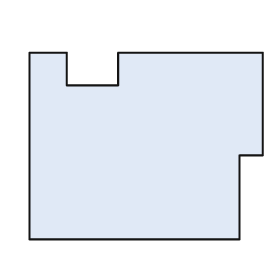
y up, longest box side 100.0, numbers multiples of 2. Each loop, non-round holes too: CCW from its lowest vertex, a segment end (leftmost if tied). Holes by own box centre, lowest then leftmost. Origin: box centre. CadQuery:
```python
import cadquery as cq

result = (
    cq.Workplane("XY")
    .moveTo(-50.0, -40.0)
    .lineTo(40.0, -40.0)
    .lineTo(40.0, -4.0)
    .lineTo(50.0, -4.0)
    .lineTo(50.0, 40.0)
    .lineTo(-12.0, 40.0)
    .lineTo(-12.0, 26.0)
    .lineTo(-34.0, 26.0)
    .lineTo(-34.0, 40.0)
    .lineTo(-50.0, 40.0)
    .close()
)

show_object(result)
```